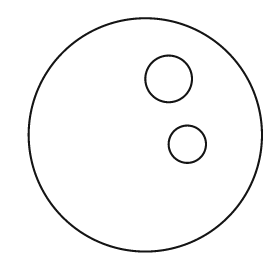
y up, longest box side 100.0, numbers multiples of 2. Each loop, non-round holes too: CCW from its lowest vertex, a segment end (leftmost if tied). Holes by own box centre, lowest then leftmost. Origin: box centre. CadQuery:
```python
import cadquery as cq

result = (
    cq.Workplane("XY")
    .moveTo(0.0, 0.0)
    .circle(50.0)
    .moveTo(18.0, -4.0)
    .circle(8.0)
    .moveTo(10.0, 24.0)
    .circle(10.0)
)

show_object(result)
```